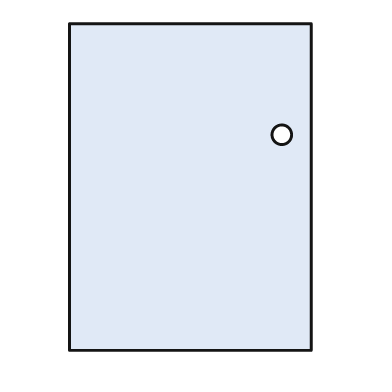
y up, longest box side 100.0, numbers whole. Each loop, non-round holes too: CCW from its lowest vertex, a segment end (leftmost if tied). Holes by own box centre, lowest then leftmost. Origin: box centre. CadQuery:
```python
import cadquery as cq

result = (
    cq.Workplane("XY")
    .moveTo(-37.0, -50.0)
    .lineTo(37.0, -50.0)
    .lineTo(37.0, 50.0)
    .lineTo(-37.0, 50.0)
    .close()
    .moveTo(28.0, 16.0)
    .circle(3.0)
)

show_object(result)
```